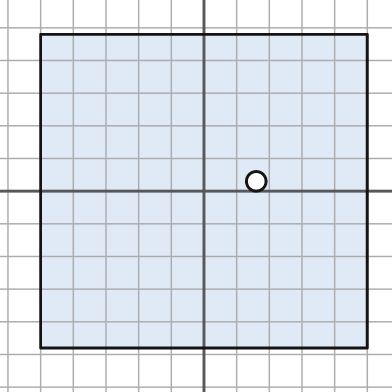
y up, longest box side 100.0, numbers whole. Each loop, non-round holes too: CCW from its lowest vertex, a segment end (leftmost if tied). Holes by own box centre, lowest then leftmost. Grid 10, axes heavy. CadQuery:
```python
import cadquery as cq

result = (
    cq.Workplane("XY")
    .moveTo(-50.0, -48.0)
    .lineTo(50.0, -48.0)
    .lineTo(50.0, 48.0)
    .lineTo(-50.0, 48.0)
    .close()
    .moveTo(16.0, 3.0)
    .circle(3.0)
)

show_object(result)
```